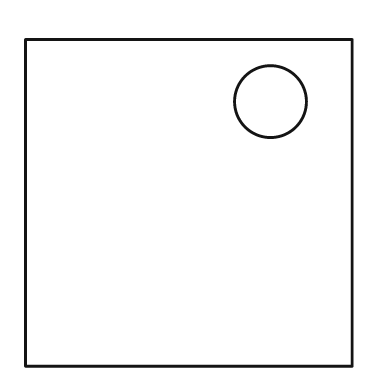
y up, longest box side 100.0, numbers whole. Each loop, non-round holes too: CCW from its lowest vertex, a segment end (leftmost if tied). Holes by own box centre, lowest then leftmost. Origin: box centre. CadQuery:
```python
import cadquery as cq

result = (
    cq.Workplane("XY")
    .moveTo(-50.0, -50.0)
    .lineTo(50.0, -50.0)
    .lineTo(50.0, 50.0)
    .lineTo(-50.0, 50.0)
    .close()
    .moveTo(25.0, 31.0)
    .circle(11.0)
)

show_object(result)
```